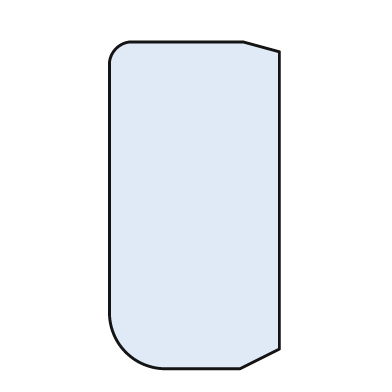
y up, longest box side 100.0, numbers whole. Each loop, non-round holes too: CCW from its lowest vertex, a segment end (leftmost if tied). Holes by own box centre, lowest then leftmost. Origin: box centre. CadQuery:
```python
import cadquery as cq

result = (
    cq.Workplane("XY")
    .moveTo(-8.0, -50.0)
    .lineTo(14.0, -50.0)
    .lineTo(26.0, -44.0)
    .lineTo(26.0, 47.0)
    .lineTo(15.0, 50.0)
    .lineTo(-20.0, 50.0)
    .threePointArc((-24.0, 48.0), (-26.0, 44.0))
    .lineTo(-26.0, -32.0)
    .threePointArc((-21.0, -45.0), (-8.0, -50.0))
    .close()
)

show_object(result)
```